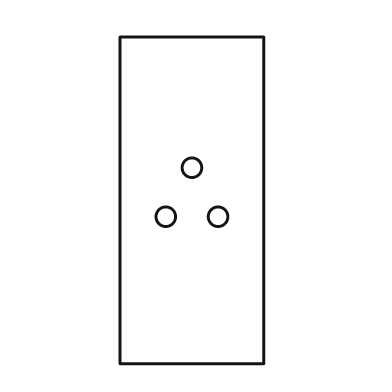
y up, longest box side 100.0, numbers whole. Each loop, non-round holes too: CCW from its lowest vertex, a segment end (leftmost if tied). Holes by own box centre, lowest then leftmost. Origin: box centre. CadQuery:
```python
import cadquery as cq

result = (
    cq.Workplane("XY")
    .moveTo(-22.0, -50.0)
    .lineTo(22.0, -50.0)
    .lineTo(22.0, 50.0)
    .lineTo(-22.0, 50.0)
    .close()
    .moveTo(-8.0, -5.0)
    .circle(3.0)
    .moveTo(8.0, -5.0)
    .circle(3.0)
    .moveTo(0.0, 10.0)
    .circle(3.0)
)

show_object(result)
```